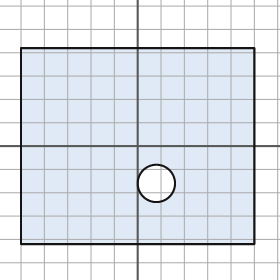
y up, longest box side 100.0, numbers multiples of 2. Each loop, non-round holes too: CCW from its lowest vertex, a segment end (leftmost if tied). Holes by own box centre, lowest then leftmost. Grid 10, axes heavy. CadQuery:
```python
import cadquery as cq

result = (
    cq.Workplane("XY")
    .moveTo(-50.0, -42.0)
    .lineTo(50.0, -42.0)
    .lineTo(50.0, 42.0)
    .lineTo(-50.0, 42.0)
    .close()
    .moveTo(8.0, -16.0)
    .circle(8.0)
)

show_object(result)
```